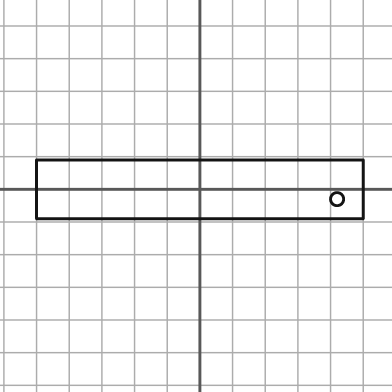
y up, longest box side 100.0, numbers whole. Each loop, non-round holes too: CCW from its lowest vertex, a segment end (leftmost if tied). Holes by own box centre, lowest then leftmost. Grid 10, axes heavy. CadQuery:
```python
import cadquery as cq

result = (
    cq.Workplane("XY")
    .moveTo(-50.0, -9.0)
    .lineTo(50.0, -9.0)
    .lineTo(50.0, 9.0)
    .lineTo(-50.0, 9.0)
    .close()
    .moveTo(42.0, -3.0)
    .circle(2.0)
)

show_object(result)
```